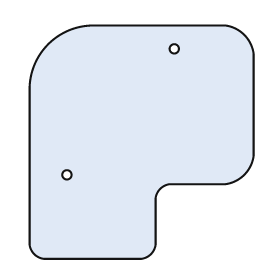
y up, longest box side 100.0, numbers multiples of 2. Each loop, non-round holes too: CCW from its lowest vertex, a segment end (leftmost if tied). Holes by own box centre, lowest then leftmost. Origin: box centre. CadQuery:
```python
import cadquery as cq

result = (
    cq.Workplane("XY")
    .moveTo(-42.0, -50.0)
    .lineTo(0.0, -50.0)
    .threePointArc((4.0, -48.0), (6.0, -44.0))
    .lineTo(6.0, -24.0)
    .threePointArc((8.0, -20.0), (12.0, -18.0))
    .lineTo(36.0, -18.0)
    .threePointArc((44.0, -14.0), (48.0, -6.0))
    .lineTo(48.0, 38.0)
    .threePointArc((44.0, 46.0), (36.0, 50.0))
    .lineTo(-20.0, 50.0)
    .threePointArc((-40.0, 42.0), (-48.0, 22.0))
    .lineTo(-48.0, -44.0)
    .threePointArc((-46.0, -48.0), (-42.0, -50.0))
    .close()
    .moveTo(-32.0, -14.0)
    .circle(2.0)
    .moveTo(14.0, 40.0)
    .circle(2.0)
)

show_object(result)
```